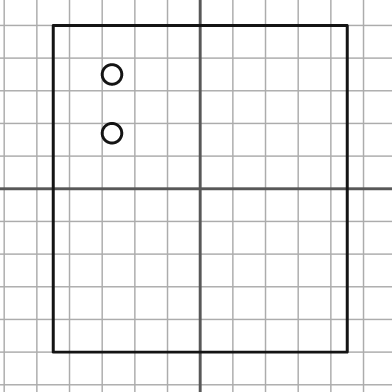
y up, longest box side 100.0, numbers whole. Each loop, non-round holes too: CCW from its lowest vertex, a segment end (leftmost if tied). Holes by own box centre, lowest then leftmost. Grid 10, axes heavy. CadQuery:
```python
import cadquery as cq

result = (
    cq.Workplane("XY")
    .moveTo(-45.0, -50.0)
    .lineTo(45.0, -50.0)
    .lineTo(45.0, 50.0)
    .lineTo(-45.0, 50.0)
    .close()
    .moveTo(-27.0, 17.0)
    .circle(3.0)
    .moveTo(-27.0, 35.0)
    .circle(3.0)
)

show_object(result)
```